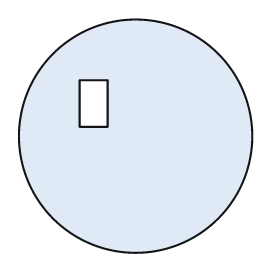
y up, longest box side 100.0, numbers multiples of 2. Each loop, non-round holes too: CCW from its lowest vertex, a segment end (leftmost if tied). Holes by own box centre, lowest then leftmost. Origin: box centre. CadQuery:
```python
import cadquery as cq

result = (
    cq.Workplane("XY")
    .moveTo(0.0, 0.0)
    .circle(50.0)
    .moveTo(-24.0, 4.0)
    .lineTo(-12.0, 4.0)
    .lineTo(-12.0, 24.0)
    .lineTo(-24.0, 24.0)
    .close()
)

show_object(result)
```